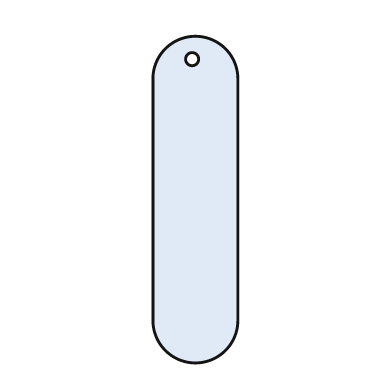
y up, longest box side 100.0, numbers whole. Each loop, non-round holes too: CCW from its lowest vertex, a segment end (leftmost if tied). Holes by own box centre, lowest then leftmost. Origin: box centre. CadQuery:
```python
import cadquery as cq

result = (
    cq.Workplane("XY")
    .moveTo(-13.0, -37.0)
    .threePointArc((0.0, -50.0), (13.0, -37.0))
    .lineTo(13.0, 37.0)
    .threePointArc((0.0, 50.0), (-13.0, 37.0))
    .close()
    .moveTo(-1.0, 43.0)
    .circle(2.0)
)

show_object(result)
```